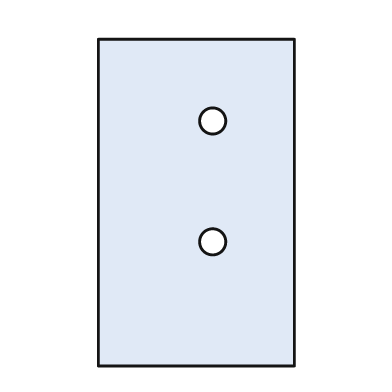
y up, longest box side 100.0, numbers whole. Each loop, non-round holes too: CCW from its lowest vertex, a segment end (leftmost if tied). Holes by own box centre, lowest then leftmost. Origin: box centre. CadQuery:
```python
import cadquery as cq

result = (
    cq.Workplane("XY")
    .moveTo(-30.0, -50.0)
    .lineTo(30.0, -50.0)
    .lineTo(30.0, 50.0)
    .lineTo(-30.0, 50.0)
    .close()
    .moveTo(5.0, -12.0)
    .circle(4.0)
    .moveTo(5.0, 25.0)
    .circle(4.0)
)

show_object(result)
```